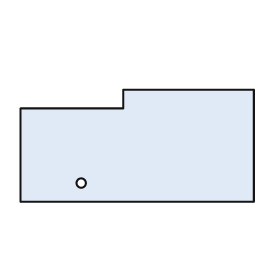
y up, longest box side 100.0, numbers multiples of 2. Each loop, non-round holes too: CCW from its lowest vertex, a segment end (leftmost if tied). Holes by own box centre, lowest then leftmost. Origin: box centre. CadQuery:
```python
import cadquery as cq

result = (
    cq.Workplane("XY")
    .moveTo(-50.0, -24.0)
    .lineTo(50.0, -24.0)
    .lineTo(50.0, 24.0)
    .lineTo(-6.0, 24.0)
    .lineTo(-6.0, 16.0)
    .lineTo(-50.0, 16.0)
    .close()
    .moveTo(-24.0, -16.0)
    .circle(2.0)
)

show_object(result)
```